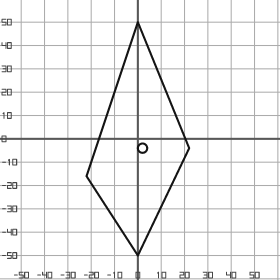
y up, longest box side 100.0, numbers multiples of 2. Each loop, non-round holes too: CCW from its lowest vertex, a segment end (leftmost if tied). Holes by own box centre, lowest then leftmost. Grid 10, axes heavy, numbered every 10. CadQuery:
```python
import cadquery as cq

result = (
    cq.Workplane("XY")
    .moveTo(0.0, -50.0)
    .lineTo(22.0, -4.0)
    .lineTo(0.0, 50.0)
    .lineTo(-22.0, -16.0)
    .close()
    .moveTo(2.0, -4.0)
    .circle(2.0)
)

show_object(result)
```